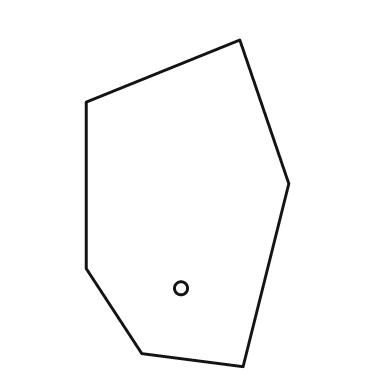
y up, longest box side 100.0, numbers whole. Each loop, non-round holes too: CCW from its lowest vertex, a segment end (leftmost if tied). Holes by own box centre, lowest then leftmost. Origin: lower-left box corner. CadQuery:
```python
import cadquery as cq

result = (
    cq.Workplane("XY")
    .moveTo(48.0, 0.0)
    .lineTo(62.0, 56.0)
    .lineTo(47.0, 100.0)
    .lineTo(0.0, 81.0)
    .lineTo(0.0, 30.0)
    .lineTo(17.0, 4.0)
    .close()
    .moveTo(29.0, 24.0)
    .circle(2.0)
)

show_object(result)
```